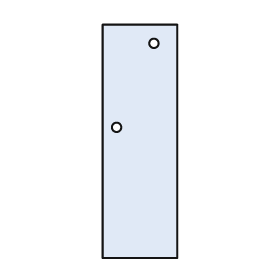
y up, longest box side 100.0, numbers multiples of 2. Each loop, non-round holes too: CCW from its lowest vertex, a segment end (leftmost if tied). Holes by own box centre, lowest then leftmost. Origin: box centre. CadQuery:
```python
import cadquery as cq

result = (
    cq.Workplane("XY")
    .moveTo(-16.0, -50.0)
    .lineTo(16.0, -50.0)
    .lineTo(16.0, 50.0)
    .lineTo(-16.0, 50.0)
    .close()
    .moveTo(-10.0, 6.0)
    .circle(2.0)
    .moveTo(6.0, 42.0)
    .circle(2.0)
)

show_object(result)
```